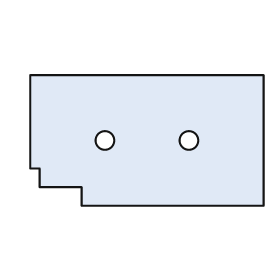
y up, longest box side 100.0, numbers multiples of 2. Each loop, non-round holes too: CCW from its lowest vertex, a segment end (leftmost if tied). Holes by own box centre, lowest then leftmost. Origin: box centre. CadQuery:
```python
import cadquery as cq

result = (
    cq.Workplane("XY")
    .moveTo(-28.0, -28.0)
    .lineTo(50.0, -28.0)
    .lineTo(50.0, 28.0)
    .lineTo(-50.0, 28.0)
    .lineTo(-50.0, -12.0)
    .lineTo(-46.0, -12.0)
    .lineTo(-46.0, -20.0)
    .lineTo(-28.0, -20.0)
    .close()
    .moveTo(-18.0, 0.0)
    .circle(4.0)
    .moveTo(18.0, 0.0)
    .circle(4.0)
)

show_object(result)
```